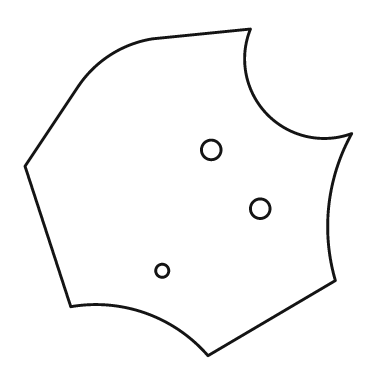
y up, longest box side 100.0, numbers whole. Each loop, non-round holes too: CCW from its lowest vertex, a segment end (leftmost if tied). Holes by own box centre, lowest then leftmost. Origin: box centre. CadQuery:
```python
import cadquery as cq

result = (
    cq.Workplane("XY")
    .moveTo(6.0, -50.0)
    .lineTo(45.0, -27.0)
    .threePointArc((43.0, -4.0), (50.0, 18.0))
    .threePointArc((24.0, 24.0), (19.0, 50.0))
    .lineTo(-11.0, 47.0)
    .threePointArc((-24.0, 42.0), (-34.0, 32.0))
    .lineTo(-50.0, 8.0)
    .lineTo(-36.0, -35.0)
    .threePointArc((-13.0, -37.0), (6.0, -50.0))
    .close()
    .moveTo(-8.0, -24.0)
    .circle(2.0)
    .moveTo(22.0, -5.0)
    .circle(3.0)
    .moveTo(7.0, 13.0)
    .circle(3.0)
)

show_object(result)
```